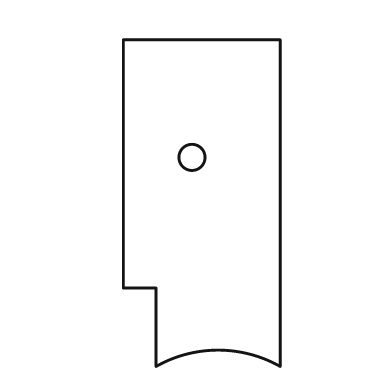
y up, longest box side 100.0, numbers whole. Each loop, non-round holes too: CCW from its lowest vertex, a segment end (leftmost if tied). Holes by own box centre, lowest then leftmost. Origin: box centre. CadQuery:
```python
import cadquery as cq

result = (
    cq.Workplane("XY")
    .moveTo(-14.0, -50.0)
    .threePointArc((5.0, -45.0), (24.0, -50.0))
    .lineTo(24.0, 50.0)
    .lineTo(-24.0, 50.0)
    .lineTo(-24.0, -26.0)
    .lineTo(-14.0, -26.0)
    .close()
    .moveTo(-3.0, 14.0)
    .circle(4.0)
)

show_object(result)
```